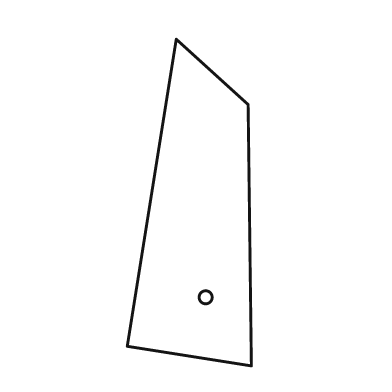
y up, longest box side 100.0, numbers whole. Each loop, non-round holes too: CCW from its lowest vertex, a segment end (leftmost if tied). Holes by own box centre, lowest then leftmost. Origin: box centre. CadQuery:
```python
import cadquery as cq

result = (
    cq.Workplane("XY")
    .moveTo(19.0, -50.0)
    .lineTo(18.0, 30.0)
    .lineTo(-4.0, 50.0)
    .lineTo(-19.0, -44.0)
    .close()
    .moveTo(5.0, -29.0)
    .circle(2.0)
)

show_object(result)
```